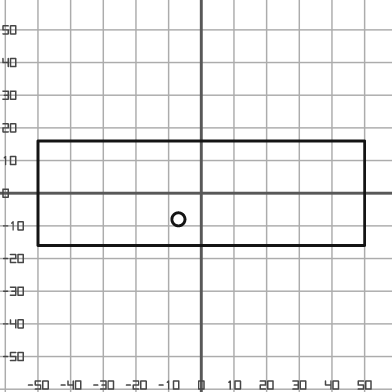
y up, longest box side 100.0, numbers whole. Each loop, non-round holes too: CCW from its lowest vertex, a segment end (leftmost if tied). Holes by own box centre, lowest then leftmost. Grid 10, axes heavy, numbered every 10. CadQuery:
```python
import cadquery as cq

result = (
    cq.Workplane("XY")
    .moveTo(-50.0, -16.0)
    .lineTo(50.0, -16.0)
    .lineTo(50.0, 16.0)
    .lineTo(-50.0, 16.0)
    .close()
    .moveTo(-7.0, -8.0)
    .circle(2.0)
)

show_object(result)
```